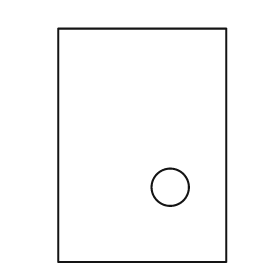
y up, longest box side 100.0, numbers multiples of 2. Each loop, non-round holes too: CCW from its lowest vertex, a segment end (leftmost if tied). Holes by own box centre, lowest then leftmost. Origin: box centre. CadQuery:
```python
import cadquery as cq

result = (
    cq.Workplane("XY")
    .moveTo(-36.0, -50.0)
    .lineTo(36.0, -50.0)
    .lineTo(36.0, 50.0)
    .lineTo(-36.0, 50.0)
    .close()
    .moveTo(12.0, -18.0)
    .circle(8.0)
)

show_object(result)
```